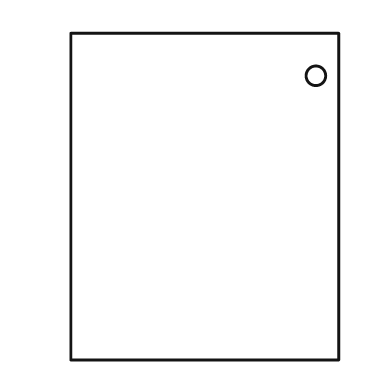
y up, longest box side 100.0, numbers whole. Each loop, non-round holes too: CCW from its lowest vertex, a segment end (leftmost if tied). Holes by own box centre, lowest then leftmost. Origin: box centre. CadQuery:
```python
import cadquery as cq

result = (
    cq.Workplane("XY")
    .moveTo(-41.0, -50.0)
    .lineTo(41.0, -50.0)
    .lineTo(41.0, 50.0)
    .lineTo(-41.0, 50.0)
    .close()
    .moveTo(34.0, 37.0)
    .circle(3.0)
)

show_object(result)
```